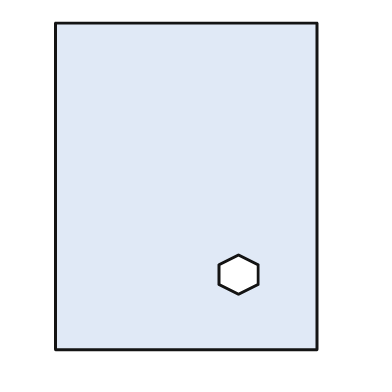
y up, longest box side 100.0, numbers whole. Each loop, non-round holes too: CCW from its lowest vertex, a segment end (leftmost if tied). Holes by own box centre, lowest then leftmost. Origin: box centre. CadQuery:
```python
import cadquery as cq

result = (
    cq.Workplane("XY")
    .moveTo(-40.0, -50.0)
    .lineTo(40.0, -50.0)
    .lineTo(40.0, 50.0)
    .lineTo(-40.0, 50.0)
    .close()
    .moveTo(16.0, -33.0)
    .lineTo(22.0, -30.0)
    .lineTo(22.0, -24.0)
    .lineTo(16.0, -21.0)
    .lineTo(10.0, -24.0)
    .lineTo(10.0, -30.0)
    .close()
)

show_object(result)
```